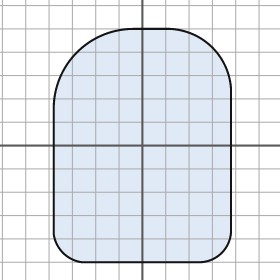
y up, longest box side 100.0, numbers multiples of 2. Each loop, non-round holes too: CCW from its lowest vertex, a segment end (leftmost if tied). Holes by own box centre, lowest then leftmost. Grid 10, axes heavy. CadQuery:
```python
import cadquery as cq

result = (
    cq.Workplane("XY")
    .moveTo(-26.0, -50.0)
    .lineTo(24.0, -50.0)
    .threePointArc((34.0, -46.0), (38.0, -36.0))
    .lineTo(38.0, 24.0)
    .threePointArc((30.0, 42.0), (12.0, 50.0))
    .lineTo(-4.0, 50.0)
    .threePointArc((-28.0, 40.0), (-38.0, 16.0))
    .lineTo(-38.0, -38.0)
    .threePointArc((-34.0, -46.0), (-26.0, -50.0))
    .close()
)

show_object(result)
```